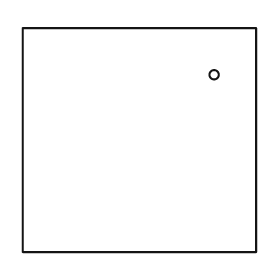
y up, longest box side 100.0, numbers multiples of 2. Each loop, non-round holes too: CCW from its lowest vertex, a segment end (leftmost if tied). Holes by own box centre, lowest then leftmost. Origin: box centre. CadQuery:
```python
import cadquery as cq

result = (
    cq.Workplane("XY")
    .moveTo(-50.0, -48.0)
    .lineTo(50.0, -48.0)
    .lineTo(50.0, 48.0)
    .lineTo(-50.0, 48.0)
    .close()
    .moveTo(32.0, 28.0)
    .circle(2.0)
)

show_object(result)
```